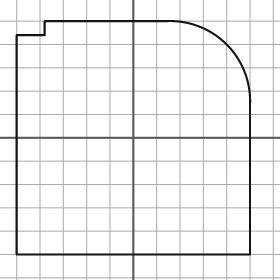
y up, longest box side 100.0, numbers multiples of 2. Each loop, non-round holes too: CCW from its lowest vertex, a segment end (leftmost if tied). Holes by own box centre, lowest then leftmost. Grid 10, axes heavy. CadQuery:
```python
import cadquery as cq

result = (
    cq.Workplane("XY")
    .moveTo(-50.0, -50.0)
    .lineTo(50.0, -50.0)
    .lineTo(50.0, 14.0)
    .threePointArc((40.0, 40.0), (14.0, 50.0))
    .lineTo(-38.0, 50.0)
    .lineTo(-38.0, 44.0)
    .lineTo(-50.0, 44.0)
    .close()
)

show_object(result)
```